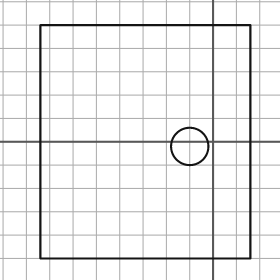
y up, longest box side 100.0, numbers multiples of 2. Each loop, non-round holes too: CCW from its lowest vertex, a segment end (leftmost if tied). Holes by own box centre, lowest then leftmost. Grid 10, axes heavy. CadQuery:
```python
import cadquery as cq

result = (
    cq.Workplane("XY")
    .moveTo(-74.0, -50.0)
    .lineTo(16.0, -50.0)
    .lineTo(16.0, 50.0)
    .lineTo(-74.0, 50.0)
    .close()
    .moveTo(-10.0, -2.0)
    .circle(8.0)
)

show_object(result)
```